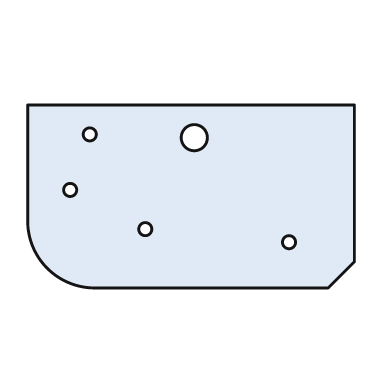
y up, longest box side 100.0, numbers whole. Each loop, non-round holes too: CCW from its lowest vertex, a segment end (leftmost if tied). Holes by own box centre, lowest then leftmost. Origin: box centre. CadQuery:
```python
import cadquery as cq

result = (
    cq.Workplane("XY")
    .moveTo(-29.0, -28.0)
    .lineTo(42.0, -28.0)
    .lineTo(50.0, -20.0)
    .lineTo(50.0, 28.0)
    .lineTo(-50.0, 28.0)
    .lineTo(-50.0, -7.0)
    .threePointArc((-44.0, -22.0), (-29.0, -28.0))
    .close()
    .moveTo(30.0, -14.0)
    .circle(2.0)
    .moveTo(-14.0, -10.0)
    .circle(2.0)
    .moveTo(-37.0, 2.0)
    .circle(2.0)
    .moveTo(1.0, 18.0)
    .circle(4.0)
    .moveTo(-31.0, 19.0)
    .circle(2.0)
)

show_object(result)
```